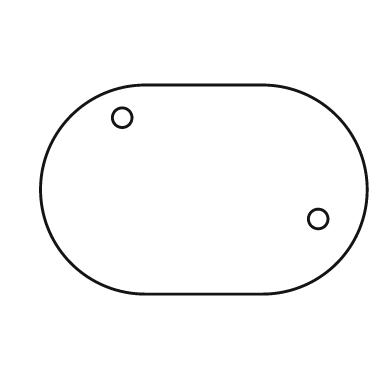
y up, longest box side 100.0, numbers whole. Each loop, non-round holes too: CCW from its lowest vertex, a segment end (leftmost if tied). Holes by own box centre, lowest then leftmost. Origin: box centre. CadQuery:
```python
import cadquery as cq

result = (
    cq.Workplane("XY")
    .moveTo(-18.0, -32.0)
    .lineTo(18.0, -32.0)
    .threePointArc((50.0, 0.0), (18.0, 32.0))
    .lineTo(-18.0, 32.0)
    .threePointArc((-50.0, 0.0), (-18.0, -32.0))
    .close()
    .moveTo(35.0, -9.0)
    .circle(3.0)
    .moveTo(-25.0, 22.0)
    .circle(3.0)
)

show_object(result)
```